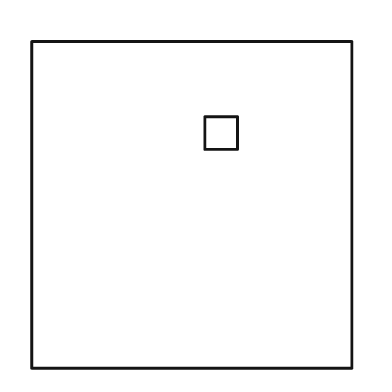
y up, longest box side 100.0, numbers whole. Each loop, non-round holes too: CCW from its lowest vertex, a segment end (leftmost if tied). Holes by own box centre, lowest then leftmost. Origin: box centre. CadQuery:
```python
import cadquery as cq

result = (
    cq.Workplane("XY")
    .moveTo(-49.0, -50.0)
    .lineTo(49.0, -50.0)
    .lineTo(49.0, 50.0)
    .lineTo(-49.0, 50.0)
    .close()
    .moveTo(4.0, 17.0)
    .lineTo(14.0, 17.0)
    .lineTo(14.0, 27.0)
    .lineTo(4.0, 27.0)
    .close()
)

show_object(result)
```